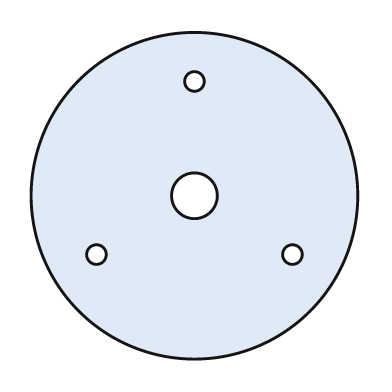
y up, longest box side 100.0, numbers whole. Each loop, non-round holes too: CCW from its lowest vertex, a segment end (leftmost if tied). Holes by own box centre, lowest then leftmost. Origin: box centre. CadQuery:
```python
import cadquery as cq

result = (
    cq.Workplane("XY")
    .moveTo(0.0, 0.0)
    .circle(50.0)
    .moveTo(-30.0, -18.0)
    .circle(3.0)
    .moveTo(30.0, -18.0)
    .circle(3.0)
    .moveTo(0.0, 0.0)
    .circle(7.0)
    .moveTo(0.0, 35.0)
    .circle(3.0)
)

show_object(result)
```